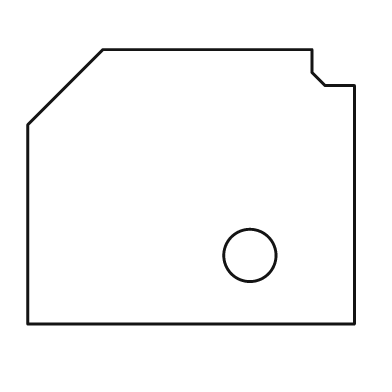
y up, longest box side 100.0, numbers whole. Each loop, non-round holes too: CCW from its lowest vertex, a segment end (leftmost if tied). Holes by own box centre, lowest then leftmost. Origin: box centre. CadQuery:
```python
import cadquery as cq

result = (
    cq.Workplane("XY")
    .moveTo(-50.0, -42.0)
    .lineTo(50.0, -42.0)
    .lineTo(50.0, 31.0)
    .lineTo(41.0, 31.0)
    .lineTo(37.0, 35.0)
    .lineTo(37.0, 42.0)
    .lineTo(-27.0, 42.0)
    .lineTo(-50.0, 19.0)
    .close()
    .moveTo(18.0, -21.0)
    .circle(8.0)
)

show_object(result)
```